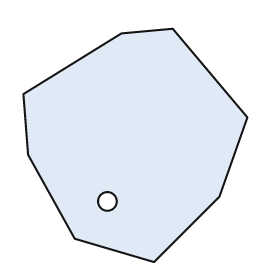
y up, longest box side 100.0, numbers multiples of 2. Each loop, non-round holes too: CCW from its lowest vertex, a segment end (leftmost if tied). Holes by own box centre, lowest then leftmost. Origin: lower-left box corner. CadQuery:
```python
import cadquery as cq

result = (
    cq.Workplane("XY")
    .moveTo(56.0, 0.0)
    .lineTo(84.0, 28.0)
    .lineTo(96.0, 62.0)
    .lineTo(64.0, 100.0)
    .lineTo(42.0, 98.0)
    .lineTo(0.0, 72.0)
    .lineTo(2.0, 46.0)
    .lineTo(22.0, 10.0)
    .close()
    .moveTo(36.0, 26.0)
    .circle(4.0)
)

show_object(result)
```